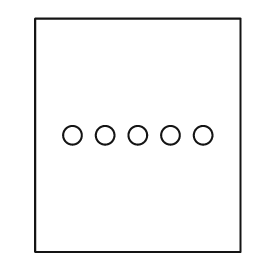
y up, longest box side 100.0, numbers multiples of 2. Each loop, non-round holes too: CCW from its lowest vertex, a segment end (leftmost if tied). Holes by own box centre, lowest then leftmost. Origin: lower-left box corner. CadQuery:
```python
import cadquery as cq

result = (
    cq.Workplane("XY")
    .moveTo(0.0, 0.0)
    .lineTo(88.0, 0.0)
    .lineTo(88.0, 100.0)
    .lineTo(0.0, 100.0)
    .close()
    .moveTo(16.0, 50.0)
    .circle(4.0)
    .moveTo(30.0, 50.0)
    .circle(4.0)
    .moveTo(44.0, 50.0)
    .circle(4.0)
    .moveTo(58.0, 50.0)
    .circle(4.0)
    .moveTo(72.0, 50.0)
    .circle(4.0)
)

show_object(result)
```